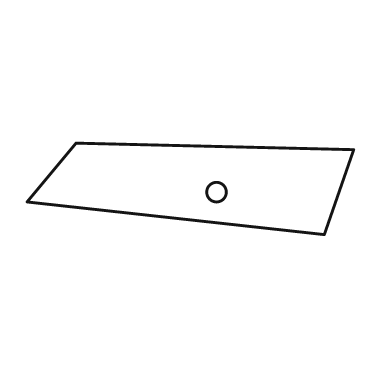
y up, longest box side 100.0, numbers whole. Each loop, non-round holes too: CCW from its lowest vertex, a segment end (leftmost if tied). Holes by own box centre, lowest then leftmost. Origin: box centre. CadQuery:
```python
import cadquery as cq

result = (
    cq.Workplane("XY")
    .moveTo(41.0, -14.0)
    .lineTo(50.0, 12.0)
    .lineTo(-35.0, 14.0)
    .lineTo(-50.0, -4.0)
    .close()
    .moveTo(8.0, -1.0)
    .circle(3.0)
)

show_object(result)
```